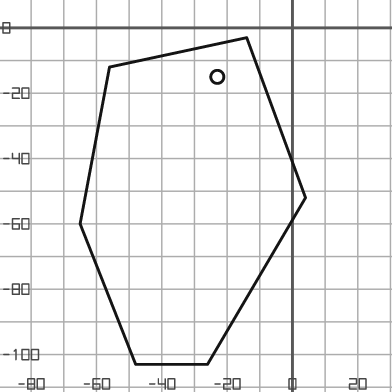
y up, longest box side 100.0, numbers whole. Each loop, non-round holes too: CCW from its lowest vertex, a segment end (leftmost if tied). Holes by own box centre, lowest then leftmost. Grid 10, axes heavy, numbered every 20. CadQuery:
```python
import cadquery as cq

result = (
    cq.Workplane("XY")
    .moveTo(-48.0, -103.0)
    .lineTo(-26.0, -103.0)
    .lineTo(4.0, -52.0)
    .lineTo(-14.0, -3.0)
    .lineTo(-56.0, -12.0)
    .lineTo(-65.0, -60.0)
    .close()
    .moveTo(-23.0, -15.0)
    .circle(2.0)
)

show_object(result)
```